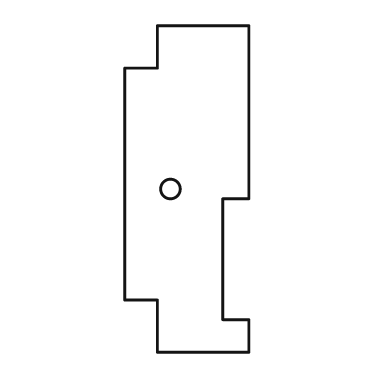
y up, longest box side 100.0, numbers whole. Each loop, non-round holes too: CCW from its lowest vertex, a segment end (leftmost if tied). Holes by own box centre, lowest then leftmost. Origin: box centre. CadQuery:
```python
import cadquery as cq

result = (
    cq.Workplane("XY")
    .moveTo(-9.0, -50.0)
    .lineTo(19.0, -50.0)
    .lineTo(19.0, -40.0)
    .lineTo(11.0, -40.0)
    .lineTo(11.0, -3.0)
    .lineTo(19.0, -3.0)
    .lineTo(19.0, 50.0)
    .lineTo(-9.0, 50.0)
    .lineTo(-9.0, 37.0)
    .lineTo(-19.0, 37.0)
    .lineTo(-19.0, -34.0)
    .lineTo(-9.0, -34.0)
    .close()
    .moveTo(-5.0, 0.0)
    .circle(3.0)
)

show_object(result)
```